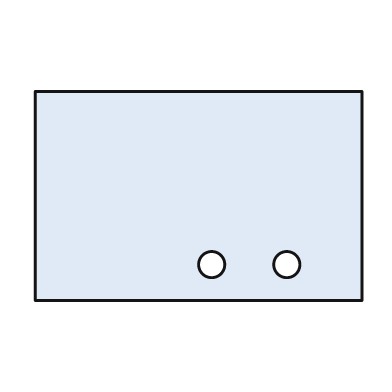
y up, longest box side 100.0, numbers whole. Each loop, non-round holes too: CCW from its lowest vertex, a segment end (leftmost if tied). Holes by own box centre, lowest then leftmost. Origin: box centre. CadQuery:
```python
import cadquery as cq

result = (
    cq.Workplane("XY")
    .moveTo(-50.0, -32.0)
    .lineTo(50.0, -32.0)
    .lineTo(50.0, 32.0)
    .lineTo(-50.0, 32.0)
    .close()
    .moveTo(4.0, -21.0)
    .circle(4.0)
    .moveTo(27.0, -21.0)
    .circle(4.0)
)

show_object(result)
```